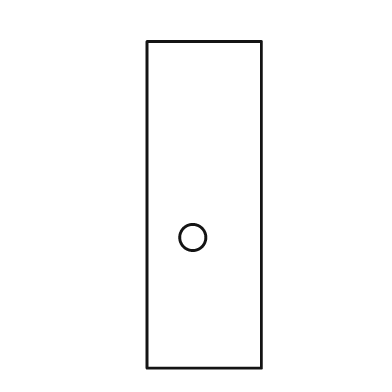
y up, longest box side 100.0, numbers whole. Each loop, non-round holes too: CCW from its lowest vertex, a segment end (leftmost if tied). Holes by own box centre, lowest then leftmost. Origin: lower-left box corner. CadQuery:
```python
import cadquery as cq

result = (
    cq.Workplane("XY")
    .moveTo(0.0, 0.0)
    .lineTo(35.0, 0.0)
    .lineTo(35.0, 100.0)
    .lineTo(0.0, 100.0)
    .close()
    .moveTo(14.0, 40.0)
    .circle(4.0)
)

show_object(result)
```